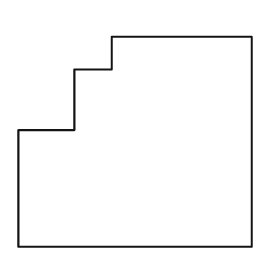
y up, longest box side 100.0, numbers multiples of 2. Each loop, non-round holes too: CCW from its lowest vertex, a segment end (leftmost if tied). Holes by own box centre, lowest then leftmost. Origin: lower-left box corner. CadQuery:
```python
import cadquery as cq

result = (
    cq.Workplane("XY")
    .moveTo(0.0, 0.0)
    .lineTo(100.0, 0.0)
    .lineTo(100.0, 90.0)
    .lineTo(40.0, 90.0)
    .lineTo(40.0, 76.0)
    .lineTo(24.0, 76.0)
    .lineTo(24.0, 50.0)
    .lineTo(0.0, 50.0)
    .close()
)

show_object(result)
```